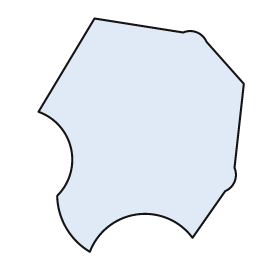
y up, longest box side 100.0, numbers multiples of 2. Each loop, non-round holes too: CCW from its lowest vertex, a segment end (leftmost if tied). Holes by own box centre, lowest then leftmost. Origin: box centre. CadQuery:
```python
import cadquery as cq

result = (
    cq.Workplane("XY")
    .moveTo(-22.0, -50.0)
    .threePointArc((-2.0, -34.0), (22.0, -44.0))
    .lineTo(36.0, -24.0)
    .threePointArc((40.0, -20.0), (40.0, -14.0))
    .lineTo(44.0, 22.0)
    .lineTo(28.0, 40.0)
    .threePointArc((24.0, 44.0), (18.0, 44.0))
    .lineTo(-20.0, 50.0)
    .lineTo(-44.0, 10.0)
    .threePointArc((-30.0, -6.0), (-36.0, -26.0))
    .threePointArc((-32.0, -40.0), (-22.0, -50.0))
    .close()
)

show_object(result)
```